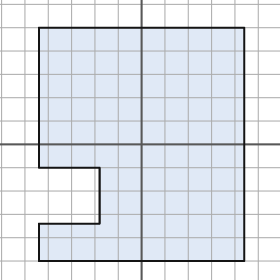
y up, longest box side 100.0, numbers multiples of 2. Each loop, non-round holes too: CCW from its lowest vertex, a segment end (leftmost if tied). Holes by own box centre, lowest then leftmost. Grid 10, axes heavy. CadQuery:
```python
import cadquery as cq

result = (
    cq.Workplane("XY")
    .moveTo(-44.0, -50.0)
    .lineTo(44.0, -50.0)
    .lineTo(44.0, 50.0)
    .lineTo(-44.0, 50.0)
    .lineTo(-44.0, -10.0)
    .lineTo(-18.0, -10.0)
    .lineTo(-18.0, -34.0)
    .lineTo(-44.0, -34.0)
    .close()
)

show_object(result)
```